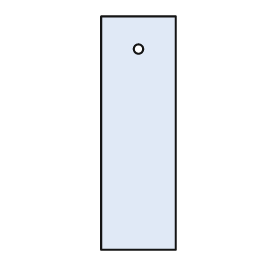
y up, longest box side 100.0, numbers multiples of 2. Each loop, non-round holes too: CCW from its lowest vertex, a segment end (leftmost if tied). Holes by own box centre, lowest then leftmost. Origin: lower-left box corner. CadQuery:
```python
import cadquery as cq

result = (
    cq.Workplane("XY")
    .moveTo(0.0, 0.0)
    .lineTo(32.0, 0.0)
    .lineTo(32.0, 100.0)
    .lineTo(0.0, 100.0)
    .close()
    .moveTo(16.0, 86.0)
    .circle(2.0)
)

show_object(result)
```